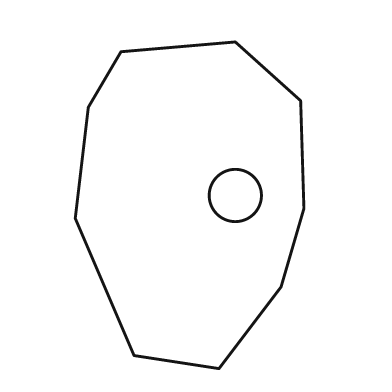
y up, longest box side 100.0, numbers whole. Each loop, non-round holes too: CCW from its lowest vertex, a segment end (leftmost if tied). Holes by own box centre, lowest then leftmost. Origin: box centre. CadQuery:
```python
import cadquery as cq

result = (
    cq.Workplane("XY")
    .moveTo(9.0, -50.0)
    .lineTo(28.0, -25.0)
    .lineTo(35.0, -1.0)
    .lineTo(34.0, 32.0)
    .lineTo(14.0, 50.0)
    .lineTo(-21.0, 47.0)
    .lineTo(-31.0, 30.0)
    .lineTo(-35.0, -4.0)
    .lineTo(-17.0, -46.0)
    .close()
    .moveTo(14.0, 3.0)
    .circle(8.0)
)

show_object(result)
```